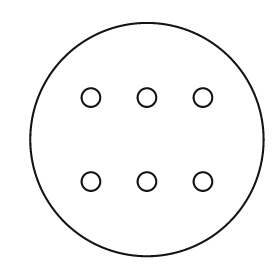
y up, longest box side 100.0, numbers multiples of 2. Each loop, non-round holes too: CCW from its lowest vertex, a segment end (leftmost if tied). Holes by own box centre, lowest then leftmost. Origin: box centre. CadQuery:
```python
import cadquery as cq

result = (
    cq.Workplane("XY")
    .moveTo(0.0, 0.0)
    .circle(50.0)
    .moveTo(-24.0, -18.0)
    .circle(4.0)
    .moveTo(0.0, -18.0)
    .circle(4.0)
    .moveTo(24.0, -18.0)
    .circle(4.0)
    .moveTo(-24.0, 18.0)
    .circle(4.0)
    .moveTo(0.0, 18.0)
    .circle(4.0)
    .moveTo(24.0, 18.0)
    .circle(4.0)
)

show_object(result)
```